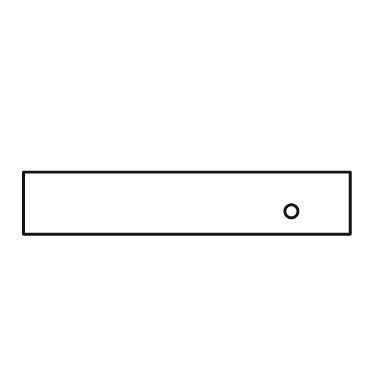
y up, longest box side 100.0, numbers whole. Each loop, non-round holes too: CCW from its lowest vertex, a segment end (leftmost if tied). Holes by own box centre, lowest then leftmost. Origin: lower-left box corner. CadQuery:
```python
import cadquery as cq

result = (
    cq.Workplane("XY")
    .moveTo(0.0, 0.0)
    .lineTo(100.0, 0.0)
    .lineTo(100.0, 19.0)
    .lineTo(0.0, 19.0)
    .close()
    .moveTo(82.0, 7.0)
    .circle(2.0)
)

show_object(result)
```